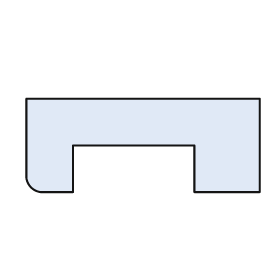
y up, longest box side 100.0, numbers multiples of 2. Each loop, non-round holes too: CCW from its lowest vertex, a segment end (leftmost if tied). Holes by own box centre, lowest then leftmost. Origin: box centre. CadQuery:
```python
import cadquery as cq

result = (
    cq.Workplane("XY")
    .moveTo(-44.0, -20.0)
    .lineTo(-30.0, -20.0)
    .lineTo(-30.0, 0.0)
    .lineTo(22.0, 0.0)
    .lineTo(22.0, -20.0)
    .lineTo(50.0, -20.0)
    .lineTo(50.0, 20.0)
    .lineTo(-50.0, 20.0)
    .lineTo(-50.0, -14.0)
    .threePointArc((-48.0, -18.0), (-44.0, -20.0))
    .close()
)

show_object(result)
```